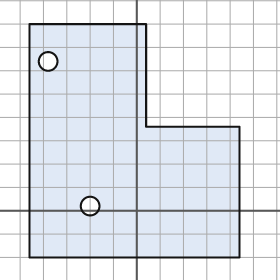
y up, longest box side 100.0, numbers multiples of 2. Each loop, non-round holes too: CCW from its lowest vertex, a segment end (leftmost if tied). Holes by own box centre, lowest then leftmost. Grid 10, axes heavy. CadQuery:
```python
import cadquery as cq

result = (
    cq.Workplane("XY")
    .moveTo(-46.0, -20.0)
    .lineTo(44.0, -20.0)
    .lineTo(44.0, 36.0)
    .lineTo(4.0, 36.0)
    .lineTo(4.0, 80.0)
    .lineTo(-46.0, 80.0)
    .close()
    .moveTo(-20.0, 2.0)
    .circle(4.0)
    .moveTo(-38.0, 64.0)
    .circle(4.0)
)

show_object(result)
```